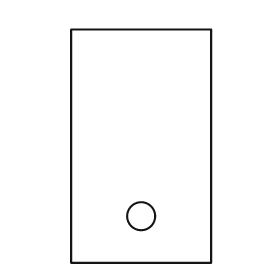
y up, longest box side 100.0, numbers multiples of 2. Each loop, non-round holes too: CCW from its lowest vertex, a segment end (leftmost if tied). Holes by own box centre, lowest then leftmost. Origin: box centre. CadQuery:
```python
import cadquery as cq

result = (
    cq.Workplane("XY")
    .moveTo(-30.0, -50.0)
    .lineTo(30.0, -50.0)
    .lineTo(30.0, 50.0)
    .lineTo(-30.0, 50.0)
    .close()
    .moveTo(0.0, -30.0)
    .circle(6.0)
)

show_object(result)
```